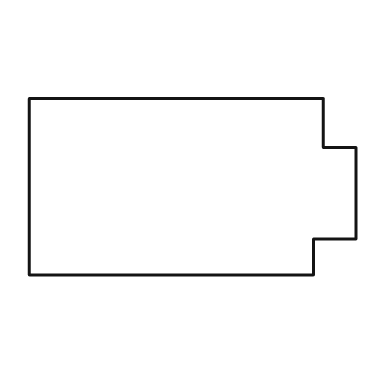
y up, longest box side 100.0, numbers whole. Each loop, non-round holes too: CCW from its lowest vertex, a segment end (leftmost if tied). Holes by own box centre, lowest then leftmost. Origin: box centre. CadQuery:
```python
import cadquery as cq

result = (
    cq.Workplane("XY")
    .moveTo(-50.0, -27.0)
    .lineTo(37.0, -27.0)
    .lineTo(37.0, -16.0)
    .lineTo(50.0, -16.0)
    .lineTo(50.0, 12.0)
    .lineTo(40.0, 12.0)
    .lineTo(40.0, 27.0)
    .lineTo(-50.0, 27.0)
    .close()
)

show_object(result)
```